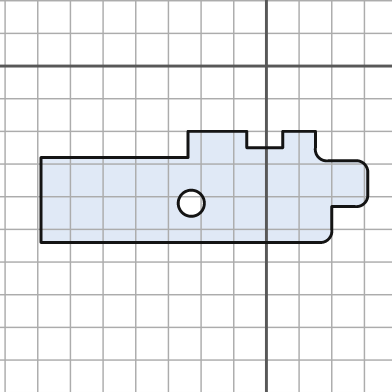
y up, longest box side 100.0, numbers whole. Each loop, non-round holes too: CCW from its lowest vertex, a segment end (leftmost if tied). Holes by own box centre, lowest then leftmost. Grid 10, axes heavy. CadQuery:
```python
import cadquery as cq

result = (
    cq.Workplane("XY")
    .moveTo(-69.0, -54.0)
    .lineTo(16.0, -54.0)
    .threePointArc((19.0, -53.0), (20.0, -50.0))
    .lineTo(20.0, -43.0)
    .lineTo(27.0, -43.0)
    .threePointArc((30.0, -42.0), (31.0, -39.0))
    .lineTo(31.0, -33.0)
    .threePointArc((30.0, -30.0), (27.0, -29.0))
    .lineTo(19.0, -29.0)
    .threePointArc((16.0, -28.0), (15.0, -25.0))
    .lineTo(15.0, -20.0)
    .lineTo(5.0, -20.0)
    .lineTo(5.0, -25.0)
    .lineTo(-6.0, -25.0)
    .lineTo(-6.0, -20.0)
    .lineTo(-24.0, -20.0)
    .lineTo(-24.0, -28.0)
    .lineTo(-69.0, -28.0)
    .close()
    .moveTo(-23.0, -42.0)
    .circle(4.0)
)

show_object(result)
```